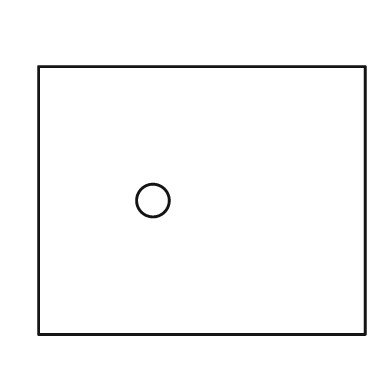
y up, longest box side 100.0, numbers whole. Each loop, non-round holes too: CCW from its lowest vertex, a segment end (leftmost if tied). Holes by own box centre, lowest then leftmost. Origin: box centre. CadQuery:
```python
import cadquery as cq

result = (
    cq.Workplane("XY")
    .moveTo(-50.0, -41.0)
    .lineTo(50.0, -41.0)
    .lineTo(50.0, 41.0)
    .lineTo(-50.0, 41.0)
    .close()
    .moveTo(-15.0, 0.0)
    .circle(5.0)
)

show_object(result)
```